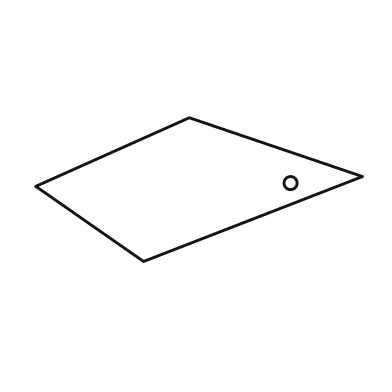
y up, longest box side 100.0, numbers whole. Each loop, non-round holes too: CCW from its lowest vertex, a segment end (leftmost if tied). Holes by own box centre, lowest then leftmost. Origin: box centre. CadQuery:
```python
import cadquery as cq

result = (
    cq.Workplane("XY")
    .moveTo(-17.0, -22.0)
    .lineTo(50.0, 4.0)
    .lineTo(-3.0, 22.0)
    .lineTo(-50.0, 1.0)
    .close()
    .moveTo(28.0, 2.0)
    .circle(2.0)
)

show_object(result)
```